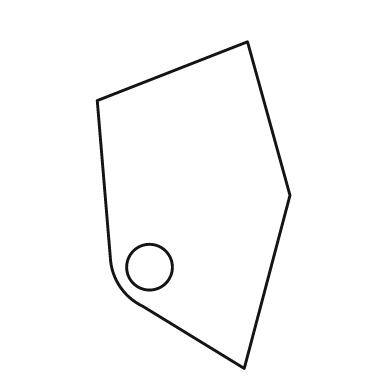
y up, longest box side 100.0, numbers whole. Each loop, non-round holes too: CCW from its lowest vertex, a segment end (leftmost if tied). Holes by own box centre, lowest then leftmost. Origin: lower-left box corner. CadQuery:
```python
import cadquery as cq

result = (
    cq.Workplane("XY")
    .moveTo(45.0, 0.0)
    .lineTo(59.0, 53.0)
    .lineTo(46.0, 100.0)
    .lineTo(0.0, 82.0)
    .lineTo(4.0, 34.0)
    .threePointArc((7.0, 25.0), (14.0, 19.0))
    .close()
    .moveTo(16.0, 31.0)
    .circle(7.0)
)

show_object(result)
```